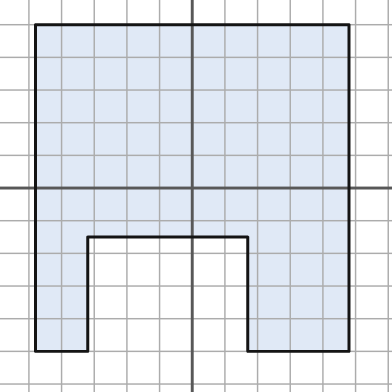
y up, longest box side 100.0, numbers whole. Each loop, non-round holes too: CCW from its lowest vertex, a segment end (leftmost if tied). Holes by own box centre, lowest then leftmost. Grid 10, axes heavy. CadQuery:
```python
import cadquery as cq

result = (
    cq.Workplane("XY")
    .moveTo(-48.0, -50.0)
    .lineTo(-32.0, -50.0)
    .lineTo(-32.0, -15.0)
    .lineTo(17.0, -15.0)
    .lineTo(17.0, -50.0)
    .lineTo(48.0, -50.0)
    .lineTo(48.0, 50.0)
    .lineTo(-48.0, 50.0)
    .close()
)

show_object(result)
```